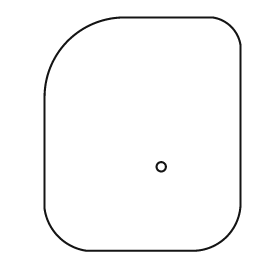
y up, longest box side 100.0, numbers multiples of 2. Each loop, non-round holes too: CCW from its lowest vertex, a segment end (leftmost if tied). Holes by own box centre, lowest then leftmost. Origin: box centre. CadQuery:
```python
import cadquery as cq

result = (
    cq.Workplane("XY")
    .moveTo(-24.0, -50.0)
    .lineTo(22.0, -50.0)
    .threePointArc((36.0, -44.0), (42.0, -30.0))
    .lineTo(42.0, 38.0)
    .threePointArc((38.0, 46.0), (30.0, 50.0))
    .lineTo(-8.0, 50.0)
    .threePointArc((-32.0, 40.0), (-42.0, 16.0))
    .lineTo(-42.0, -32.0)
    .threePointArc((-36.0, -44.0), (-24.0, -50.0))
    .close()
    .moveTo(8.0, -14.0)
    .circle(2.0)
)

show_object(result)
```